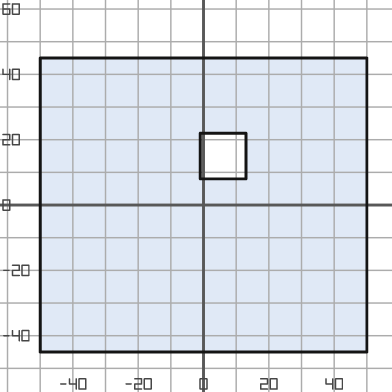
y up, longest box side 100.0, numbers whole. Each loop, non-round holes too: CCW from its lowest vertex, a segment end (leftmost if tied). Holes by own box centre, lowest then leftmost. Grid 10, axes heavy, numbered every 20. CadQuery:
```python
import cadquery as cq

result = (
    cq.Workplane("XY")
    .moveTo(-50.0, -45.0)
    .lineTo(50.0, -45.0)
    .lineTo(50.0, 45.0)
    .lineTo(-50.0, 45.0)
    .close()
    .moveTo(-1.0, 8.0)
    .lineTo(13.0, 8.0)
    .lineTo(13.0, 22.0)
    .lineTo(-1.0, 22.0)
    .close()
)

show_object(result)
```